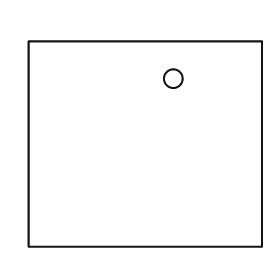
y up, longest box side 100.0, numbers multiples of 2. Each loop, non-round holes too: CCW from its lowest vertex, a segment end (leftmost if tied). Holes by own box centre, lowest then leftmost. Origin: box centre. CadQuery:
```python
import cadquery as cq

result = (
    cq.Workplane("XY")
    .moveTo(-50.0, -44.0)
    .lineTo(50.0, -44.0)
    .lineTo(50.0, 44.0)
    .lineTo(-50.0, 44.0)
    .close()
    .moveTo(12.0, 28.0)
    .circle(4.0)
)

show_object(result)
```